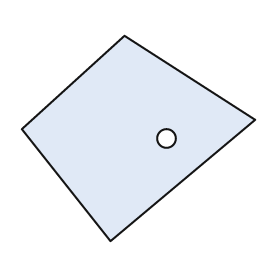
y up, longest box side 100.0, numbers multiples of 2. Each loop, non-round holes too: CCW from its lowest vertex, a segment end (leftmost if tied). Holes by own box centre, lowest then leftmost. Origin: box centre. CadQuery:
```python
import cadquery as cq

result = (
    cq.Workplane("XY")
    .moveTo(-12.0, -44.0)
    .lineTo(50.0, 8.0)
    .lineTo(-6.0, 44.0)
    .lineTo(-50.0, 4.0)
    .close()
    .moveTo(12.0, 0.0)
    .circle(4.0)
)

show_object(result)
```